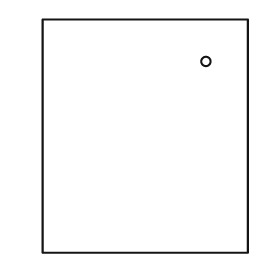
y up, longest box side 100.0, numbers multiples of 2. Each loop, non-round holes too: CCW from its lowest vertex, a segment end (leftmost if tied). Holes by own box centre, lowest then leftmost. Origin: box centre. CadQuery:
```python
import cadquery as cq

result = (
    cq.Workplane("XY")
    .moveTo(-44.0, -50.0)
    .lineTo(44.0, -50.0)
    .lineTo(44.0, 50.0)
    .lineTo(-44.0, 50.0)
    .close()
    .moveTo(26.0, 32.0)
    .circle(2.0)
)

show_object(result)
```